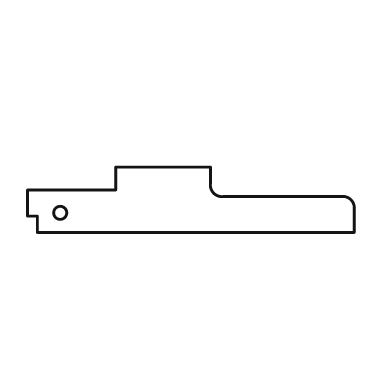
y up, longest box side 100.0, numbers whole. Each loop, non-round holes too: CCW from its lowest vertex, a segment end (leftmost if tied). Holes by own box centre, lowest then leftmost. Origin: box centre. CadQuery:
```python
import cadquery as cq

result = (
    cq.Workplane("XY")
    .moveTo(-47.0, -10.0)
    .lineTo(50.0, -10.0)
    .lineTo(50.0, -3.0)
    .threePointArc((49.0, 0.0), (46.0, 1.0))
    .lineTo(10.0, 1.0)
    .threePointArc((7.0, 2.0), (6.0, 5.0))
    .lineTo(6.0, 10.0)
    .lineTo(-23.0, 10.0)
    .lineTo(-23.0, 3.0)
    .lineTo(-50.0, 3.0)
    .lineTo(-50.0, -5.0)
    .lineTo(-47.0, -5.0)
    .close()
    .moveTo(-40.0, -4.0)
    .circle(2.0)
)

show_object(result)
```